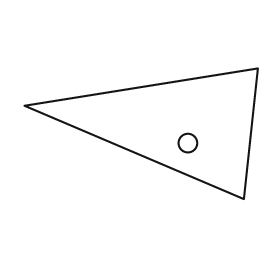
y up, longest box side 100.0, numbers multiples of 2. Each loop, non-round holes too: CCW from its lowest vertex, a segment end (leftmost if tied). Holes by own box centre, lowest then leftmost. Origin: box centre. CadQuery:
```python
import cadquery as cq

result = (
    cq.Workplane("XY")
    .moveTo(44.0, -28.0)
    .lineTo(50.0, 28.0)
    .lineTo(-50.0, 12.0)
    .close()
    .moveTo(20.0, -4.0)
    .circle(4.0)
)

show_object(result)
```